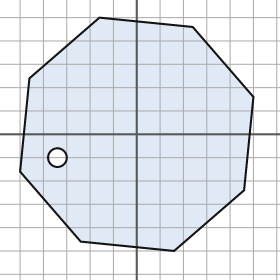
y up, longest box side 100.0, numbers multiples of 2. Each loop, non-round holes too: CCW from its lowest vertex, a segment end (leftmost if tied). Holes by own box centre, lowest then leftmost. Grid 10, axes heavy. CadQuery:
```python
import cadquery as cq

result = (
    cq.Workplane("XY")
    .moveTo(16.0, -50.0)
    .lineTo(46.0, -24.0)
    .lineTo(50.0, 16.0)
    .lineTo(24.0, 46.0)
    .lineTo(-16.0, 50.0)
    .lineTo(-46.0, 24.0)
    .lineTo(-50.0, -16.0)
    .lineTo(-24.0, -46.0)
    .close()
    .moveTo(-34.0, -10.0)
    .circle(4.0)
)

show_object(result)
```